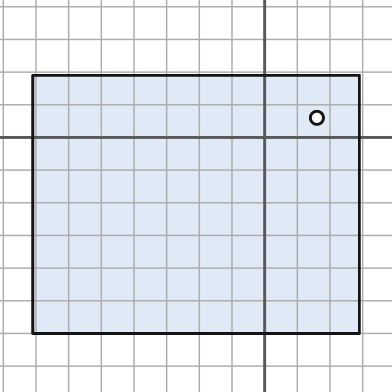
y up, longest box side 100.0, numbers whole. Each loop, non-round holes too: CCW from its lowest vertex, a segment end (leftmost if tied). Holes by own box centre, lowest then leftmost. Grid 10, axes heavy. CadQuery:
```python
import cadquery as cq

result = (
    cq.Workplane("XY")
    .moveTo(-71.0, -60.0)
    .lineTo(29.0, -60.0)
    .lineTo(29.0, 19.0)
    .lineTo(-71.0, 19.0)
    .close()
    .moveTo(16.0, 6.0)
    .circle(2.0)
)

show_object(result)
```